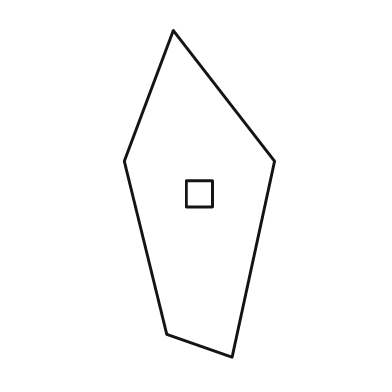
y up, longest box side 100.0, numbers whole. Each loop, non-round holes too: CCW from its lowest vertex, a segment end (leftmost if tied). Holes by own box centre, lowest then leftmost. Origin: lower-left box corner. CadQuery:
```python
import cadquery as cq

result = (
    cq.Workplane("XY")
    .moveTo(33.0, 0.0)
    .lineTo(46.0, 60.0)
    .lineTo(15.0, 100.0)
    .lineTo(0.0, 60.0)
    .lineTo(13.0, 7.0)
    .close()
    .moveTo(19.0, 46.0)
    .lineTo(27.0, 46.0)
    .lineTo(27.0, 54.0)
    .lineTo(19.0, 54.0)
    .close()
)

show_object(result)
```